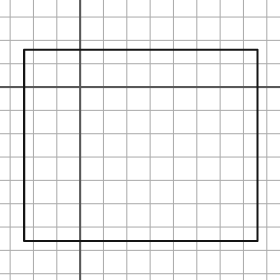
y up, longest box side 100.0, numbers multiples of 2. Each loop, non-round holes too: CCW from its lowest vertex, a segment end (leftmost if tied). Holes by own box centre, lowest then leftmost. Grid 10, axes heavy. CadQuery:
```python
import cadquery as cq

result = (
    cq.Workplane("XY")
    .moveTo(-24.0, -66.0)
    .lineTo(76.0, -66.0)
    .lineTo(76.0, 16.0)
    .lineTo(-24.0, 16.0)
    .close()
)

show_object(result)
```